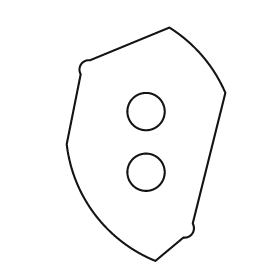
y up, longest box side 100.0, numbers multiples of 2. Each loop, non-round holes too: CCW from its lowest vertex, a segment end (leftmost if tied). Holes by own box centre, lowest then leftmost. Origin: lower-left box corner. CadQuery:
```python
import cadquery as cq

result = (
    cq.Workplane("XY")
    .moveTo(38.0, 0.0)
    .lineTo(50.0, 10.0)
    .threePointArc((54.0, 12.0), (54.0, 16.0))
    .lineTo(68.0, 72.0)
    .threePointArc((58.0, 88.0), (44.0, 100.0))
    .lineTo(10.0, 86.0)
    .threePointArc((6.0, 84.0), (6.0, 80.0))
    .lineTo(0.0, 50.0)
    .threePointArc((12.0, 20.0), (38.0, 0.0))
    .close()
    .moveTo(34.0, 38.0)
    .circle(8.0)
    .moveTo(34.0, 64.0)
    .circle(8.0)
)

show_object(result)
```